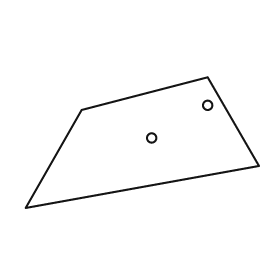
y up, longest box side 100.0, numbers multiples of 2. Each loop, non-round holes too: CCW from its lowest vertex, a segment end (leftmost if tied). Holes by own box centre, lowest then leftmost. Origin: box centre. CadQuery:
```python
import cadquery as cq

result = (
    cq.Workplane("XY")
    .moveTo(-50.0, -28.0)
    .lineTo(50.0, -10.0)
    .lineTo(28.0, 28.0)
    .lineTo(-26.0, 14.0)
    .close()
    .moveTo(4.0, 2.0)
    .circle(2.0)
    .moveTo(28.0, 16.0)
    .circle(2.0)
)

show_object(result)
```